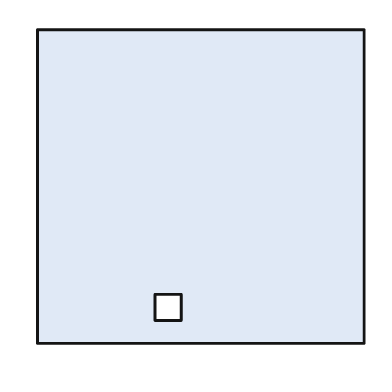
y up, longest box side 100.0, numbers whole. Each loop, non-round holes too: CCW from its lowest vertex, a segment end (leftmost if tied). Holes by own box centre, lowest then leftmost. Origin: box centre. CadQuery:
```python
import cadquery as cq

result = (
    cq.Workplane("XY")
    .moveTo(-50.0, -48.0)
    .lineTo(50.0, -48.0)
    .lineTo(50.0, 48.0)
    .lineTo(-50.0, 48.0)
    .close()
    .moveTo(-14.0, -41.0)
    .lineTo(-6.0, -41.0)
    .lineTo(-6.0, -33.0)
    .lineTo(-14.0, -33.0)
    .close()
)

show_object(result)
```